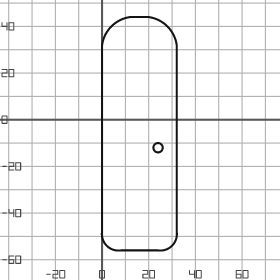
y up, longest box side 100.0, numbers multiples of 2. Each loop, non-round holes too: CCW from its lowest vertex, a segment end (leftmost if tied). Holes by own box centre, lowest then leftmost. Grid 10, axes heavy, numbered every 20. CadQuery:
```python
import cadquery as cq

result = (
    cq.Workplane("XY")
    .moveTo(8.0, -56.0)
    .lineTo(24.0, -56.0)
    .threePointArc((30.0, -54.0), (32.0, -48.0))
    .lineTo(32.0, 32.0)
    .threePointArc((28.0, 40.0), (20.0, 44.0))
    .lineTo(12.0, 44.0)
    .threePointArc((4.0, 40.0), (0.0, 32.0))
    .lineTo(0.0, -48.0)
    .threePointArc((2.0, -54.0), (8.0, -56.0))
    .close()
    .moveTo(24.0, -12.0)
    .circle(2.0)
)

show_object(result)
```